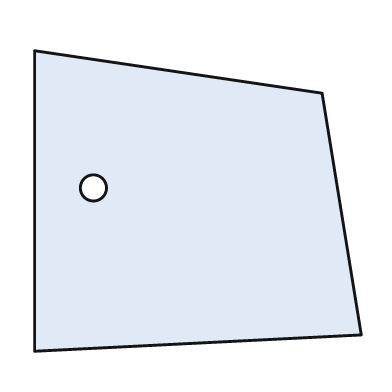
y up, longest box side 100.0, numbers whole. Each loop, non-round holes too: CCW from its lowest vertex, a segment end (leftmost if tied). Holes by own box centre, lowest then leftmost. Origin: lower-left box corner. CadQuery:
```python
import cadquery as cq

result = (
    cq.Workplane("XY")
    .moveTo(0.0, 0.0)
    .lineTo(100.0, 5.0)
    .lineTo(88.0, 79.0)
    .lineTo(0.0, 92.0)
    .close()
    .moveTo(18.0, 50.0)
    .circle(4.0)
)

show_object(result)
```